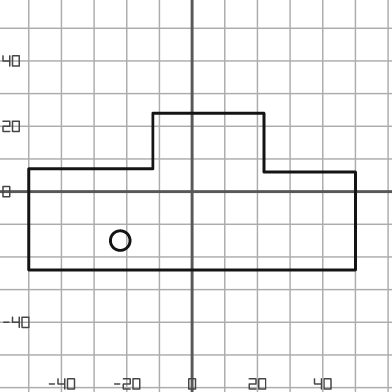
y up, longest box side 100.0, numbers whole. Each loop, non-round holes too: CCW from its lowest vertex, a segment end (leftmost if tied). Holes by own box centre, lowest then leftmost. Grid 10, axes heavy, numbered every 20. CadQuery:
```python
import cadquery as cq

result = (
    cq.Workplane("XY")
    .moveTo(-50.0, -24.0)
    .lineTo(50.0, -24.0)
    .lineTo(50.0, 6.0)
    .lineTo(22.0, 6.0)
    .lineTo(22.0, 24.0)
    .lineTo(-12.0, 24.0)
    .lineTo(-12.0, 7.0)
    .lineTo(-50.0, 7.0)
    .close()
    .moveTo(-22.0, -15.0)
    .circle(3.0)
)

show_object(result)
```